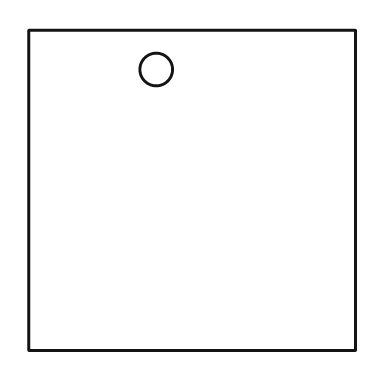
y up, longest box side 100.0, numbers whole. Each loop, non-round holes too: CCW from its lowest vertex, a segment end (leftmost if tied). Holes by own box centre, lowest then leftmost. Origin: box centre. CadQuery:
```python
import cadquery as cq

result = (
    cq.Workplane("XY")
    .moveTo(-50.0, -49.0)
    .lineTo(50.0, -49.0)
    .lineTo(50.0, 49.0)
    .lineTo(-50.0, 49.0)
    .close()
    .moveTo(-11.0, 37.0)
    .circle(5.0)
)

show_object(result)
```